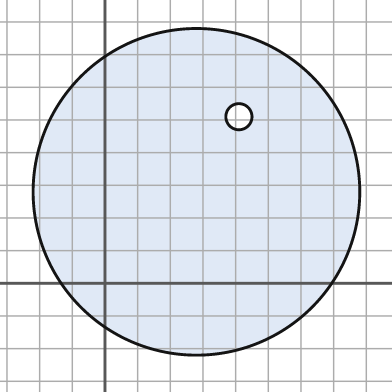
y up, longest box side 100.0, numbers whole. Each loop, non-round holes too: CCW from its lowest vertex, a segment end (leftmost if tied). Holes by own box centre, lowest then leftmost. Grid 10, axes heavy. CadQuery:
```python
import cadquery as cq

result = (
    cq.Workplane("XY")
    .moveTo(28.0, 28.0)
    .circle(50.0)
    .moveTo(41.0, 51.0)
    .circle(4.0)
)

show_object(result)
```